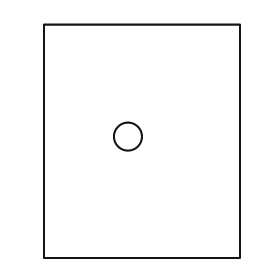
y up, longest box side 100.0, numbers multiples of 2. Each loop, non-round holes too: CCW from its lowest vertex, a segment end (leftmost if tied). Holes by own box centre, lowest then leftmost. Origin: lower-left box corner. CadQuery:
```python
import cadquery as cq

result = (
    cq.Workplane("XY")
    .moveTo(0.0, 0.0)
    .lineTo(84.0, 0.0)
    .lineTo(84.0, 100.0)
    .lineTo(0.0, 100.0)
    .close()
    .moveTo(36.0, 52.0)
    .circle(6.0)
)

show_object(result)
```